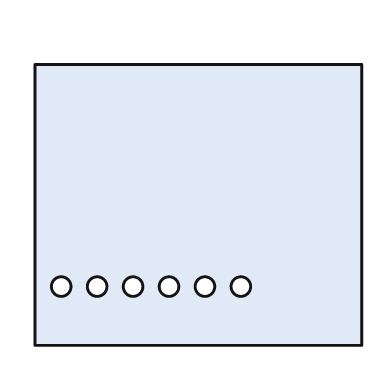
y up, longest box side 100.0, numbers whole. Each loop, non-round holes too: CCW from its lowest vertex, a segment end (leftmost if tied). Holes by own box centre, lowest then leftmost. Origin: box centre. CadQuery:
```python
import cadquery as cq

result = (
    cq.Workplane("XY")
    .moveTo(-50.0, -43.0)
    .lineTo(50.0, -43.0)
    .lineTo(50.0, 43.0)
    .lineTo(-50.0, 43.0)
    .close()
    .moveTo(-42.0, -25.0)
    .circle(3.0)
    .moveTo(-31.0, -25.0)
    .circle(3.0)
    .moveTo(-20.0, -25.0)
    .circle(3.0)
    .moveTo(-9.0, -25.0)
    .circle(3.0)
    .moveTo(2.0, -25.0)
    .circle(3.0)
    .moveTo(13.0, -25.0)
    .circle(3.0)
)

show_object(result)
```